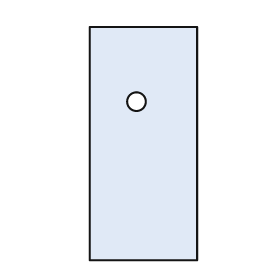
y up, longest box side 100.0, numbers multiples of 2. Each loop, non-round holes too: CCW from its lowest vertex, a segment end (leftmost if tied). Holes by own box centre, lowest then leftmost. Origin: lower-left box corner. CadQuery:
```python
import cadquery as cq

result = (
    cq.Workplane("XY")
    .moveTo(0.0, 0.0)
    .lineTo(46.0, 0.0)
    .lineTo(46.0, 100.0)
    .lineTo(0.0, 100.0)
    .close()
    .moveTo(20.0, 68.0)
    .circle(4.0)
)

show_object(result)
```